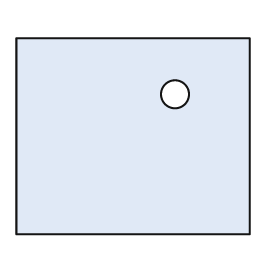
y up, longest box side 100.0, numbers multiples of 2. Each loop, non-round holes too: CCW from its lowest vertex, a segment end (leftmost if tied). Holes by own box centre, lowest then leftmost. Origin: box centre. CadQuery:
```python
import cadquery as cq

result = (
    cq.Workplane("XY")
    .moveTo(-50.0, -42.0)
    .lineTo(50.0, -42.0)
    .lineTo(50.0, 42.0)
    .lineTo(-50.0, 42.0)
    .close()
    .moveTo(18.0, 18.0)
    .circle(6.0)
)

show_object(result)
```